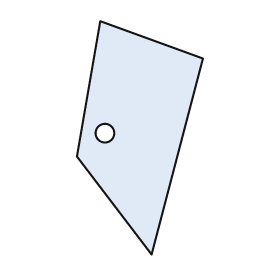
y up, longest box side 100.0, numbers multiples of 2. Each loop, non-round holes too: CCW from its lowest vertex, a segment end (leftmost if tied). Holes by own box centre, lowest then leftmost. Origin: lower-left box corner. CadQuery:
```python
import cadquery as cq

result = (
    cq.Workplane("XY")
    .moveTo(32.0, 0.0)
    .lineTo(54.0, 84.0)
    .lineTo(10.0, 100.0)
    .lineTo(0.0, 42.0)
    .close()
    .moveTo(12.0, 52.0)
    .circle(4.0)
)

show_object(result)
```